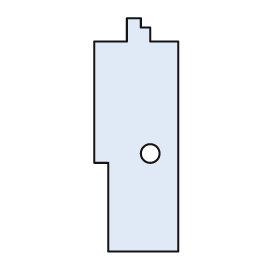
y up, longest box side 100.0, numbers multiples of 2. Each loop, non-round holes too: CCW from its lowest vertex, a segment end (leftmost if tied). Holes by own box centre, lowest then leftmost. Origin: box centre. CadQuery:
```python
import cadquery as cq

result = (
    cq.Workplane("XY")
    .moveTo(-12.0, -50.0)
    .lineTo(18.0, -50.0)
    .lineTo(18.0, 40.0)
    .lineTo(6.0, 40.0)
    .lineTo(6.0, 46.0)
    .lineTo(2.0, 46.0)
    .lineTo(2.0, 50.0)
    .lineTo(-4.0, 50.0)
    .lineTo(-4.0, 40.0)
    .lineTo(-18.0, 40.0)
    .lineTo(-18.0, -12.0)
    .lineTo(-12.0, -12.0)
    .close()
    .moveTo(6.0, -8.0)
    .circle(4.0)
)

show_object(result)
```